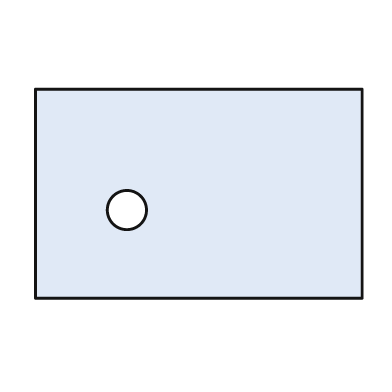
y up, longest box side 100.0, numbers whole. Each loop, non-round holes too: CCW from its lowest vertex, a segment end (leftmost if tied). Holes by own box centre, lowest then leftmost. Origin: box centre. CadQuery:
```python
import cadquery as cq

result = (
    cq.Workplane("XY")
    .moveTo(-50.0, -32.0)
    .lineTo(50.0, -32.0)
    .lineTo(50.0, 32.0)
    .lineTo(-50.0, 32.0)
    .close()
    .moveTo(-22.0, -5.0)
    .circle(6.0)
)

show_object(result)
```